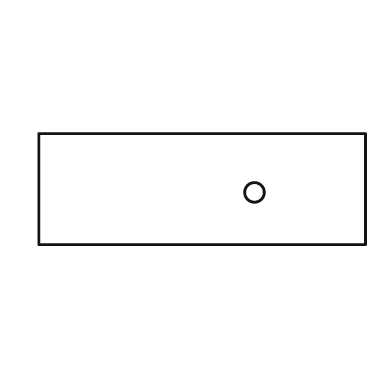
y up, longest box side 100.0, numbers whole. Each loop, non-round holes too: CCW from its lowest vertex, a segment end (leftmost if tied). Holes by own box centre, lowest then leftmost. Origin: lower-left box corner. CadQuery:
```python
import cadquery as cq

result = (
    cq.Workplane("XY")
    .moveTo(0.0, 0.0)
    .lineTo(100.0, 0.0)
    .lineTo(100.0, 34.0)
    .lineTo(0.0, 34.0)
    .close()
    .moveTo(66.0, 16.0)
    .circle(3.0)
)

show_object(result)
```